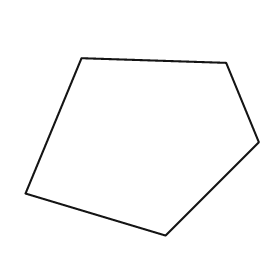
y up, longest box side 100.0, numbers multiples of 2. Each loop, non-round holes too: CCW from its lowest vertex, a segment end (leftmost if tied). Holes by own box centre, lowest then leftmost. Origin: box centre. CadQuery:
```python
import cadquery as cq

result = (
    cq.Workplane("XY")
    .moveTo(10.0, -38.0)
    .lineTo(50.0, 2.0)
    .lineTo(36.0, 36.0)
    .lineTo(-26.0, 38.0)
    .lineTo(-50.0, -20.0)
    .close()
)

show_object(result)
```